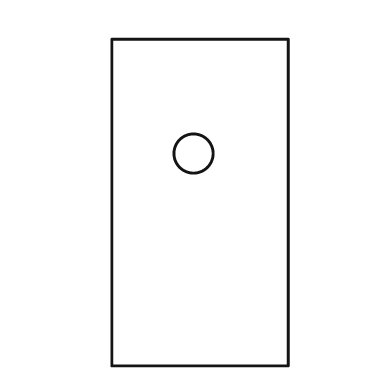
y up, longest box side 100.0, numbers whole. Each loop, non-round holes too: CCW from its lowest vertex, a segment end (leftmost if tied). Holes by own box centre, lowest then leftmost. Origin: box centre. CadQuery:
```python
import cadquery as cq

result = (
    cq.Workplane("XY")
    .moveTo(-27.0, -50.0)
    .lineTo(27.0, -50.0)
    .lineTo(27.0, 50.0)
    .lineTo(-27.0, 50.0)
    .close()
    .moveTo(-2.0, 15.0)
    .circle(6.0)
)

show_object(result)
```